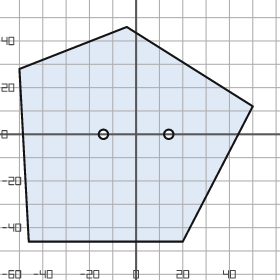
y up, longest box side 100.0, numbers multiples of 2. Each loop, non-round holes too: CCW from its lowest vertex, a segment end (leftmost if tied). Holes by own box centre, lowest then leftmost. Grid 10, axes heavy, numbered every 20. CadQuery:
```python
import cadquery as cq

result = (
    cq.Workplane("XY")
    .moveTo(-46.0, -46.0)
    .lineTo(20.0, -46.0)
    .lineTo(50.0, 12.0)
    .lineTo(-4.0, 46.0)
    .lineTo(-50.0, 28.0)
    .close()
    .moveTo(-14.0, 0.0)
    .circle(2.0)
    .moveTo(14.0, 0.0)
    .circle(2.0)
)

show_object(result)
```